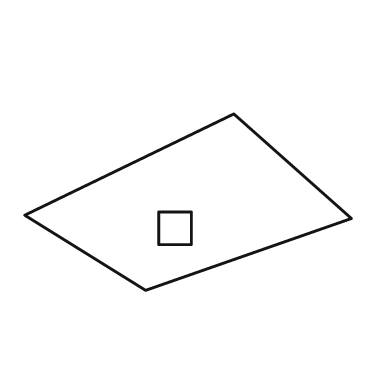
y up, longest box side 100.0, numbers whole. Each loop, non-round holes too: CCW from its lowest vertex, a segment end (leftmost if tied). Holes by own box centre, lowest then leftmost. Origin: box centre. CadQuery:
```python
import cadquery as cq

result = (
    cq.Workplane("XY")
    .moveTo(-13.0, -27.0)
    .lineTo(50.0, -5.0)
    .lineTo(14.0, 27.0)
    .lineTo(-50.0, -4.0)
    .close()
    .moveTo(-9.0, -13.0)
    .lineTo(1.0, -13.0)
    .lineTo(1.0, -3.0)
    .lineTo(-9.0, -3.0)
    .close()
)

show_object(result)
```